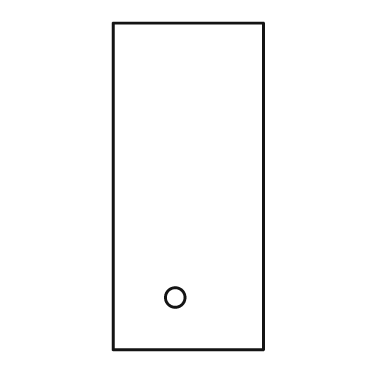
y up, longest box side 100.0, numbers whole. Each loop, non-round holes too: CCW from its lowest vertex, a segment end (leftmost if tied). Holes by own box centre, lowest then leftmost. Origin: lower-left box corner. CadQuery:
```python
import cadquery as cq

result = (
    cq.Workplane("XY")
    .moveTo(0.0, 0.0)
    .lineTo(46.0, 0.0)
    .lineTo(46.0, 100.0)
    .lineTo(0.0, 100.0)
    .close()
    .moveTo(19.0, 16.0)
    .circle(3.0)
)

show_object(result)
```